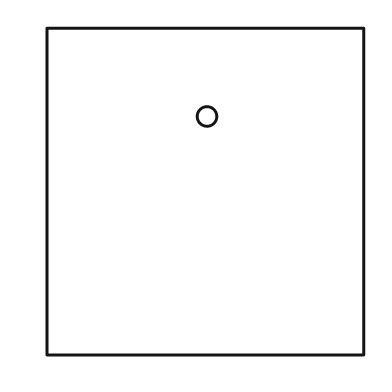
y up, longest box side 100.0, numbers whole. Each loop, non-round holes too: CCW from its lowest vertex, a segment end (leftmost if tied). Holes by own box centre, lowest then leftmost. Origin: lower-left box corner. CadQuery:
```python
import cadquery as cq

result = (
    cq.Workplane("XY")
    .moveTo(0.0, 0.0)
    .lineTo(97.0, 0.0)
    .lineTo(97.0, 100.0)
    .lineTo(0.0, 100.0)
    .close()
    .moveTo(49.0, 73.0)
    .circle(3.0)
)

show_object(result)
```